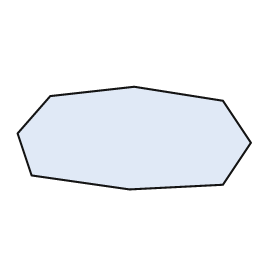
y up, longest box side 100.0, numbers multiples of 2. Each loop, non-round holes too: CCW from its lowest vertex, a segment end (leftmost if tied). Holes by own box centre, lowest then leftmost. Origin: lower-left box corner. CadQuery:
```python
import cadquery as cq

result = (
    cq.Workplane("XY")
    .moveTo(48.0, 0.0)
    .lineTo(88.0, 2.0)
    .lineTo(100.0, 20.0)
    .lineTo(88.0, 38.0)
    .lineTo(50.0, 44.0)
    .lineTo(14.0, 40.0)
    .lineTo(0.0, 24.0)
    .lineTo(6.0, 6.0)
    .close()
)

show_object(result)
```